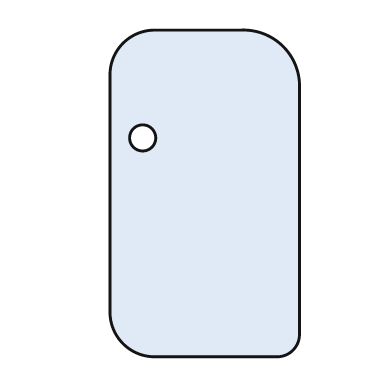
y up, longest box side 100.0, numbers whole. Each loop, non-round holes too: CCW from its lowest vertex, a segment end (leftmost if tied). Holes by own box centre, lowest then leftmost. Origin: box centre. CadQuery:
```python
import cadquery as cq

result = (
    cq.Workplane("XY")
    .moveTo(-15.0, -50.0)
    .lineTo(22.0, -50.0)
    .threePointArc((27.0, -48.0), (29.0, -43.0))
    .lineTo(29.0, 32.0)
    .threePointArc((24.0, 45.0), (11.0, 50.0))
    .lineTo(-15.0, 50.0)
    .threePointArc((-25.0, 46.0), (-29.0, 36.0))
    .lineTo(-29.0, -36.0)
    .threePointArc((-25.0, -46.0), (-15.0, -50.0))
    .close()
    .moveTo(-19.0, 17.0)
    .circle(4.0)
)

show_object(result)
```